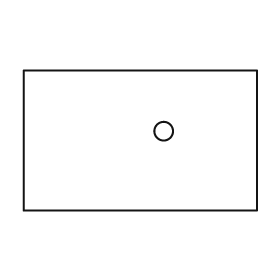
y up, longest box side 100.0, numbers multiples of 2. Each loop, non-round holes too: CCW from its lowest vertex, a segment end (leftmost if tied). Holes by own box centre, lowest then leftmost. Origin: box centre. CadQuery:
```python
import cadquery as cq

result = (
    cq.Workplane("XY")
    .moveTo(-50.0, -30.0)
    .lineTo(50.0, -30.0)
    .lineTo(50.0, 30.0)
    .lineTo(-50.0, 30.0)
    .close()
    .moveTo(10.0, 4.0)
    .circle(4.0)
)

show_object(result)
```